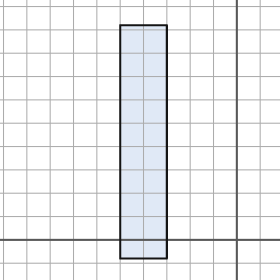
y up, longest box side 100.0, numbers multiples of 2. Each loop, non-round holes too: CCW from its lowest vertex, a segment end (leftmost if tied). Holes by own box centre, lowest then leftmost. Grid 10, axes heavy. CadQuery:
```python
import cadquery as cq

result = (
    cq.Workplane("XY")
    .moveTo(-50.0, -8.0)
    .lineTo(-30.0, -8.0)
    .lineTo(-30.0, 92.0)
    .lineTo(-50.0, 92.0)
    .close()
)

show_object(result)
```